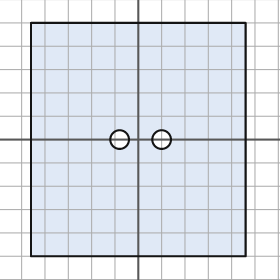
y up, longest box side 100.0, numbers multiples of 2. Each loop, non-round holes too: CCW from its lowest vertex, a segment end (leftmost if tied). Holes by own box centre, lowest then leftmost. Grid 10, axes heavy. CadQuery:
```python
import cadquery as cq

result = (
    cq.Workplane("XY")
    .moveTo(-46.0, -50.0)
    .lineTo(46.0, -50.0)
    .lineTo(46.0, 50.0)
    .lineTo(-46.0, 50.0)
    .close()
    .moveTo(-8.0, 0.0)
    .circle(4.0)
    .moveTo(10.0, 0.0)
    .circle(4.0)
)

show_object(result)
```